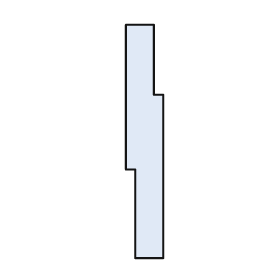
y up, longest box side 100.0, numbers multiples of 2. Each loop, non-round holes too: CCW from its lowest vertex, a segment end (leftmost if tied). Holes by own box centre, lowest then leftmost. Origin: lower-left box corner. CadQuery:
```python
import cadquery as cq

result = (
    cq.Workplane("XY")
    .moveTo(4.0, 0.0)
    .lineTo(16.0, 0.0)
    .lineTo(16.0, 70.0)
    .lineTo(12.0, 70.0)
    .lineTo(12.0, 100.0)
    .lineTo(0.0, 100.0)
    .lineTo(0.0, 38.0)
    .lineTo(4.0, 38.0)
    .close()
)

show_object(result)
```